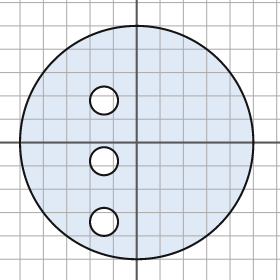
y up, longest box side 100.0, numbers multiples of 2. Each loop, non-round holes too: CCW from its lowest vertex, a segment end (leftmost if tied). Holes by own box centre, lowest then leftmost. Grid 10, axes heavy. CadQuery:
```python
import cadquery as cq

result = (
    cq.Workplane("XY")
    .moveTo(0.0, 0.0)
    .circle(50.0)
    .moveTo(-14.0, -34.0)
    .circle(6.0)
    .moveTo(-14.0, -8.0)
    .circle(6.0)
    .moveTo(-14.0, 18.0)
    .circle(6.0)
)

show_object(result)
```